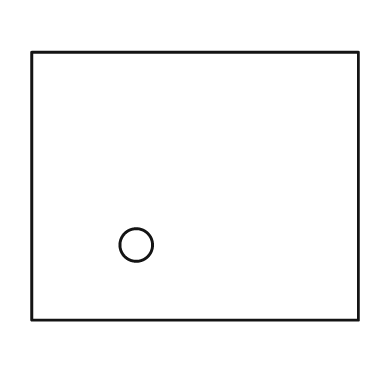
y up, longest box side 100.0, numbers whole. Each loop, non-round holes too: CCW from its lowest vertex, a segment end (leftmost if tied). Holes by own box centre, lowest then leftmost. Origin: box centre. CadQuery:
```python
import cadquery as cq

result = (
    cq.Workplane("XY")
    .moveTo(-50.0, -41.0)
    .lineTo(50.0, -41.0)
    .lineTo(50.0, 41.0)
    .lineTo(-50.0, 41.0)
    .close()
    .moveTo(-18.0, -18.0)
    .circle(5.0)
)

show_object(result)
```